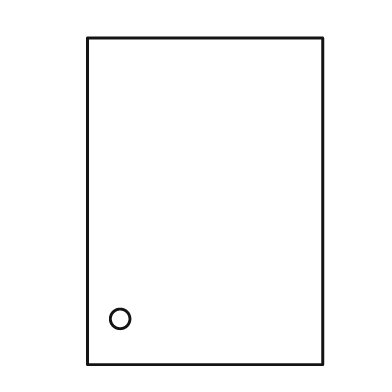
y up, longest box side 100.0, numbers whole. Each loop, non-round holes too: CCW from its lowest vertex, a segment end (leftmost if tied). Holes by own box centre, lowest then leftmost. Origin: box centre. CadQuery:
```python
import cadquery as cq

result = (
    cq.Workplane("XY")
    .moveTo(-36.0, -50.0)
    .lineTo(36.0, -50.0)
    .lineTo(36.0, 50.0)
    .lineTo(-36.0, 50.0)
    .close()
    .moveTo(-26.0, -36.0)
    .circle(3.0)
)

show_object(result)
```